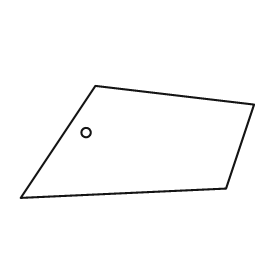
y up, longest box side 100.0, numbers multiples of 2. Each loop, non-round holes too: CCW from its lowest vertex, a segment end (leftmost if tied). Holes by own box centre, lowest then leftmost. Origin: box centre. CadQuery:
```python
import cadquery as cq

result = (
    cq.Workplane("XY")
    .moveTo(-50.0, -24.0)
    .lineTo(38.0, -20.0)
    .lineTo(50.0, 16.0)
    .lineTo(-18.0, 24.0)
    .close()
    .moveTo(-22.0, 4.0)
    .circle(2.0)
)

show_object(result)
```